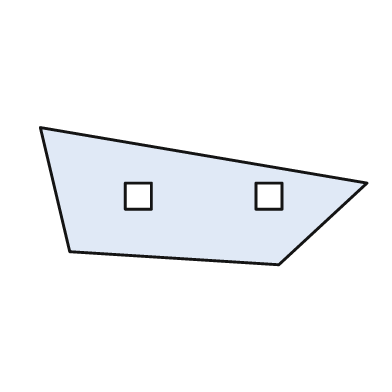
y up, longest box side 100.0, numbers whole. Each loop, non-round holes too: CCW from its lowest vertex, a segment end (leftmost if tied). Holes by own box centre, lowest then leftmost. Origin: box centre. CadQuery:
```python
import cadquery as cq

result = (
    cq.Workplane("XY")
    .moveTo(23.0, -21.0)
    .lineTo(50.0, 4.0)
    .lineTo(-50.0, 21.0)
    .lineTo(-41.0, -17.0)
    .close()
    .moveTo(-24.0, -4.0)
    .lineTo(-16.0, -4.0)
    .lineTo(-16.0, 4.0)
    .lineTo(-24.0, 4.0)
    .close()
    .moveTo(16.0, -4.0)
    .lineTo(24.0, -4.0)
    .lineTo(24.0, 4.0)
    .lineTo(16.0, 4.0)
    .close()
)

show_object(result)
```